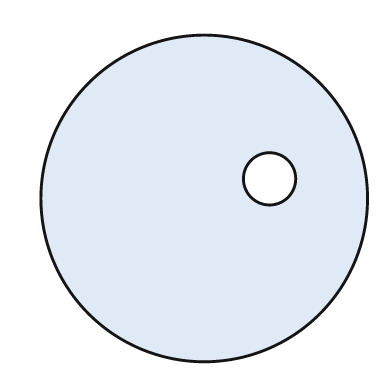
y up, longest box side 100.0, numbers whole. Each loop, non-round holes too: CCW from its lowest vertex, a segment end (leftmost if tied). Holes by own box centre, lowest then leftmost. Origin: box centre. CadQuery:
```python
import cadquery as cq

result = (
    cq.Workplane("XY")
    .moveTo(0.0, 0.0)
    .circle(50.0)
    .moveTo(20.0, 6.0)
    .circle(8.0)
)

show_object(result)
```